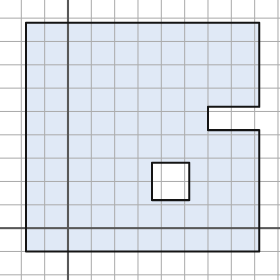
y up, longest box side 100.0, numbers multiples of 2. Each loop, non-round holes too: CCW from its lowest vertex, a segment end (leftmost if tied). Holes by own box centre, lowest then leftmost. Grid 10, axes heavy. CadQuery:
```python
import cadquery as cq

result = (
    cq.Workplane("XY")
    .moveTo(-18.0, -10.0)
    .lineTo(82.0, -10.0)
    .lineTo(82.0, 42.0)
    .lineTo(60.0, 42.0)
    .lineTo(60.0, 52.0)
    .lineTo(82.0, 52.0)
    .lineTo(82.0, 88.0)
    .lineTo(-18.0, 88.0)
    .close()
    .moveTo(36.0, 12.0)
    .lineTo(52.0, 12.0)
    .lineTo(52.0, 28.0)
    .lineTo(36.0, 28.0)
    .close()
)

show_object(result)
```